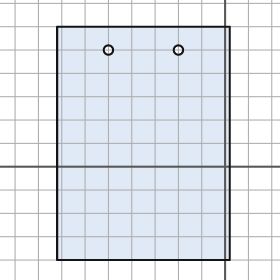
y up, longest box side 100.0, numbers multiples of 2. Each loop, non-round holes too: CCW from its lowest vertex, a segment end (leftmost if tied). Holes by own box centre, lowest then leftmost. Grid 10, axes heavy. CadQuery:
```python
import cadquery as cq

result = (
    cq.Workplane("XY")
    .moveTo(-72.0, -40.0)
    .lineTo(2.0, -40.0)
    .lineTo(2.0, 60.0)
    .lineTo(-72.0, 60.0)
    .close()
    .moveTo(-50.0, 50.0)
    .circle(2.0)
    .moveTo(-20.0, 50.0)
    .circle(2.0)
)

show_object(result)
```